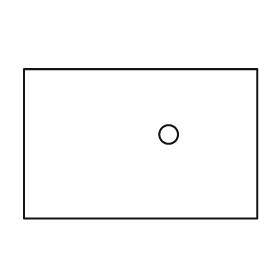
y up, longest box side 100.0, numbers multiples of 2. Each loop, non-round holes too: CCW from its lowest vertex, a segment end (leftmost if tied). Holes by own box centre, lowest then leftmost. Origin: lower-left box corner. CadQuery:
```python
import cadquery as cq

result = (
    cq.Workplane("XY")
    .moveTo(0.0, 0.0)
    .lineTo(100.0, 0.0)
    .lineTo(100.0, 64.0)
    .lineTo(0.0, 64.0)
    .close()
    .moveTo(62.0, 36.0)
    .circle(4.0)
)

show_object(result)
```